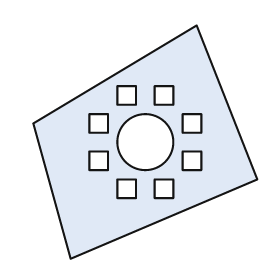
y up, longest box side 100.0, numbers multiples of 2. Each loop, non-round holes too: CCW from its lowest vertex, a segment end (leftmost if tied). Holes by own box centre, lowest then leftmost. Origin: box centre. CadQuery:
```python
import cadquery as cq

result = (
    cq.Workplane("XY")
    .moveTo(-32.0, -50.0)
    .lineTo(48.0, -16.0)
    .lineTo(22.0, 50.0)
    .lineTo(-48.0, 8.0)
    .close()
    .moveTo(-12.0, -24.0)
    .lineTo(-4.0, -24.0)
    .lineTo(-4.0, -16.0)
    .lineTo(-12.0, -16.0)
    .close()
    .moveTo(4.0, -24.0)
    .lineTo(12.0, -24.0)
    .lineTo(12.0, -16.0)
    .lineTo(4.0, -16.0)
    .close()
    .moveTo(-24.0, -12.0)
    .lineTo(-16.0, -12.0)
    .lineTo(-16.0, -4.0)
    .lineTo(-24.0, -4.0)
    .close()
    .moveTo(16.0, -12.0)
    .lineTo(24.0, -12.0)
    .lineTo(24.0, -4.0)
    .lineTo(16.0, -4.0)
    .close()
    .moveTo(0.0, 0.0)
    .circle(12.0)
    .moveTo(-24.0, 4.0)
    .lineTo(-16.0, 4.0)
    .lineTo(-16.0, 12.0)
    .lineTo(-24.0, 12.0)
    .close()
    .moveTo(16.0, 4.0)
    .lineTo(24.0, 4.0)
    .lineTo(24.0, 12.0)
    .lineTo(16.0, 12.0)
    .close()
    .moveTo(-12.0, 16.0)
    .lineTo(-4.0, 16.0)
    .lineTo(-4.0, 24.0)
    .lineTo(-12.0, 24.0)
    .close()
    .moveTo(4.0, 16.0)
    .lineTo(12.0, 16.0)
    .lineTo(12.0, 24.0)
    .lineTo(4.0, 24.0)
    .close()
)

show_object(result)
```